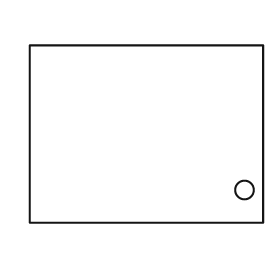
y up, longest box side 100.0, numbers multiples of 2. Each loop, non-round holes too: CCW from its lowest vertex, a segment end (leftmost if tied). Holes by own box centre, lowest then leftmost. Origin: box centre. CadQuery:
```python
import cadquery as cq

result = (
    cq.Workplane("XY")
    .moveTo(-50.0, -38.0)
    .lineTo(50.0, -38.0)
    .lineTo(50.0, 38.0)
    .lineTo(-50.0, 38.0)
    .close()
    .moveTo(42.0, -24.0)
    .circle(4.0)
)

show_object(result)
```